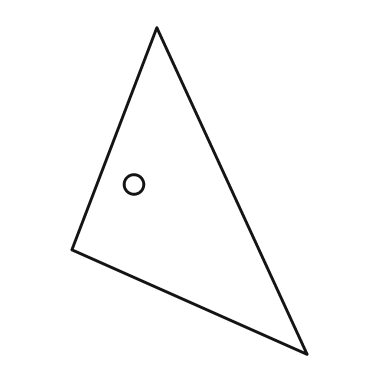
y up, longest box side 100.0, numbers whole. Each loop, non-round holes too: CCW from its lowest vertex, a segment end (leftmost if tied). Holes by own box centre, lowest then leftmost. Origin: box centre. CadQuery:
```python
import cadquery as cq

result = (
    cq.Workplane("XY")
    .moveTo(36.0, -50.0)
    .lineTo(-10.0, 50.0)
    .lineTo(-36.0, -18.0)
    .close()
    .moveTo(-17.0, 2.0)
    .circle(3.0)
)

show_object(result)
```